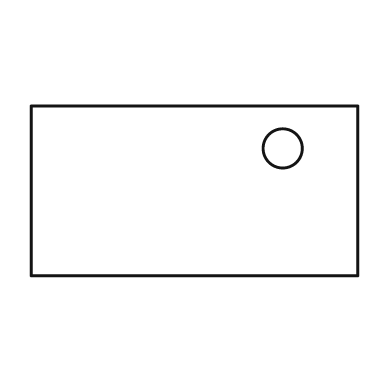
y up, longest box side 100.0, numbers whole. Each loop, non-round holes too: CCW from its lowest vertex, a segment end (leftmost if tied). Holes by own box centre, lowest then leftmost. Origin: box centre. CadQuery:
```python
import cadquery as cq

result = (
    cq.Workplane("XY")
    .moveTo(-50.0, -26.0)
    .lineTo(50.0, -26.0)
    .lineTo(50.0, 26.0)
    .lineTo(-50.0, 26.0)
    .close()
    .moveTo(27.0, 13.0)
    .circle(6.0)
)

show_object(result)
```